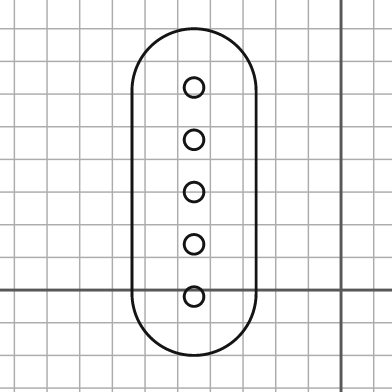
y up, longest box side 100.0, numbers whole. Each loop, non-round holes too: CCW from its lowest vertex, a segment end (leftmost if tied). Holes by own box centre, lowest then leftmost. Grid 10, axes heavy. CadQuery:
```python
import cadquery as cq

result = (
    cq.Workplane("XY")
    .moveTo(-64.0, -1.0)
    .threePointArc((-45.0, -20.0), (-26.0, -1.0))
    .lineTo(-26.0, 61.0)
    .threePointArc((-45.0, 80.0), (-64.0, 61.0))
    .close()
    .moveTo(-45.0, -2.0)
    .circle(3.0)
    .moveTo(-45.0, 14.0)
    .circle(3.0)
    .moveTo(-45.0, 30.0)
    .circle(3.0)
    .moveTo(-45.0, 46.0)
    .circle(3.0)
    .moveTo(-45.0, 62.0)
    .circle(3.0)
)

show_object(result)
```